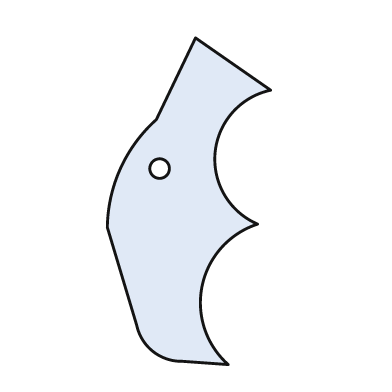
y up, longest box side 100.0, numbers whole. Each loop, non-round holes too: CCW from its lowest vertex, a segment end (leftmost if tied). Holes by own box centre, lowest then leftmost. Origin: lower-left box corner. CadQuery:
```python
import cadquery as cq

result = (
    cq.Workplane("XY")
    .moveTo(37.0, 0.0)
    .threePointArc((29.0, 24.0), (46.0, 43.0))
    .threePointArc((33.0, 65.0), (50.0, 84.0))
    .lineTo(27.0, 100.0)
    .lineTo(15.0, 75.0)
    .threePointArc((4.0, 60.0), (0.0, 42.0))
    .lineTo(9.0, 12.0)
    .threePointArc((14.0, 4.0), (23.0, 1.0))
    .close()
    .moveTo(16.0, 60.0)
    .circle(3.0)
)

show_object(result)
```